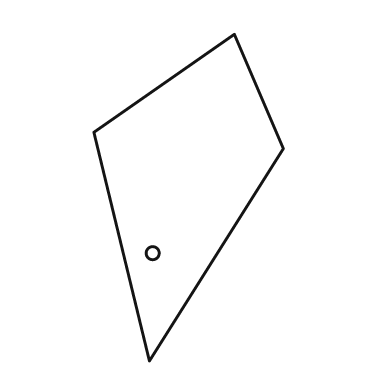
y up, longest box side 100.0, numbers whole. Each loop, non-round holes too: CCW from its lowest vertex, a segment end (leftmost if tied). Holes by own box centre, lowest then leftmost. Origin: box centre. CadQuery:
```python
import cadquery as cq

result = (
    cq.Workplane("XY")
    .moveTo(-12.0, -50.0)
    .lineTo(29.0, 15.0)
    .lineTo(14.0, 50.0)
    .lineTo(-29.0, 20.0)
    .close()
    .moveTo(-11.0, -17.0)
    .circle(2.0)
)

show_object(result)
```